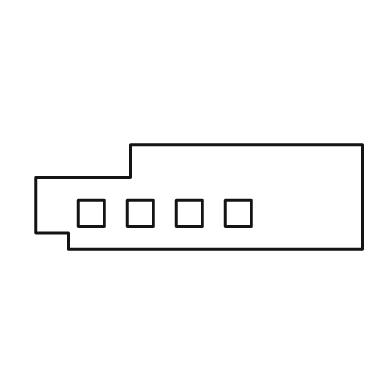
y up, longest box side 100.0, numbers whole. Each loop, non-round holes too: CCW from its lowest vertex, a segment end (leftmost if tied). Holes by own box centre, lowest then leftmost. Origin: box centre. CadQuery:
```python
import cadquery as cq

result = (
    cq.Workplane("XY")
    .moveTo(-40.0, -16.0)
    .lineTo(50.0, -16.0)
    .lineTo(50.0, 16.0)
    .lineTo(-21.0, 16.0)
    .lineTo(-21.0, 6.0)
    .lineTo(-50.0, 6.0)
    .lineTo(-50.0, -11.0)
    .lineTo(-40.0, -11.0)
    .close()
    .moveTo(-37.0, -9.0)
    .lineTo(-29.0, -9.0)
    .lineTo(-29.0, -1.0)
    .lineTo(-37.0, -1.0)
    .close()
    .moveTo(-22.0, -9.0)
    .lineTo(-14.0, -9.0)
    .lineTo(-14.0, -1.0)
    .lineTo(-22.0, -1.0)
    .close()
    .moveTo(-7.0, -9.0)
    .lineTo(1.0, -9.0)
    .lineTo(1.0, -1.0)
    .lineTo(-7.0, -1.0)
    .close()
    .moveTo(8.0, -9.0)
    .lineTo(16.0, -9.0)
    .lineTo(16.0, -1.0)
    .lineTo(8.0, -1.0)
    .close()
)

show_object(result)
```